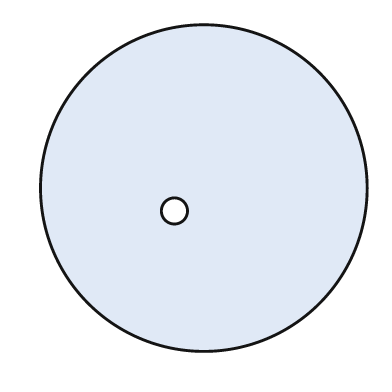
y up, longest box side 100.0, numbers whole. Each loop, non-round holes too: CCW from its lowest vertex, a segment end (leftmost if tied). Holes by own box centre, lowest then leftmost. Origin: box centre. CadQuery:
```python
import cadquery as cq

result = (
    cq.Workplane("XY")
    .moveTo(0.0, 0.0)
    .circle(50.0)
    .moveTo(-9.0, -7.0)
    .circle(4.0)
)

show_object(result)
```